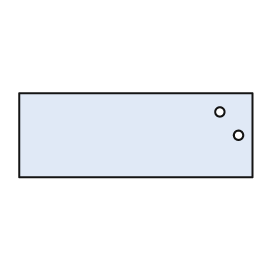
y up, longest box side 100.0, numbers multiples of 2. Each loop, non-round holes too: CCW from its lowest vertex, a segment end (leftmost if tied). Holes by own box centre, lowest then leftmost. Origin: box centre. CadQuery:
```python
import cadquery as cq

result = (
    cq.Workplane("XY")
    .moveTo(-50.0, -18.0)
    .lineTo(50.0, -18.0)
    .lineTo(50.0, 18.0)
    .lineTo(-50.0, 18.0)
    .close()
    .moveTo(44.0, 0.0)
    .circle(2.0)
    .moveTo(36.0, 10.0)
    .circle(2.0)
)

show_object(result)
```